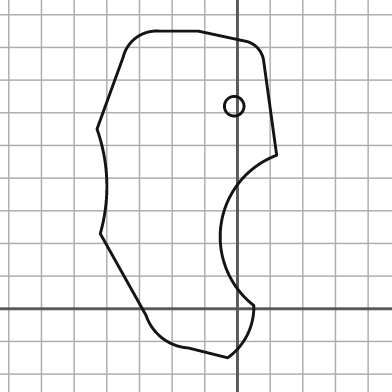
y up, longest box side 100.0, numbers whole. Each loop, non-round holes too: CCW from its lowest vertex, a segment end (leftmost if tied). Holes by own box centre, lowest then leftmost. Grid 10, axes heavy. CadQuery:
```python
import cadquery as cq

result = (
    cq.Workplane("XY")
    .moveTo(-3.0, -15.0)
    .threePointArc((3.0, -8.0), (5.0, 1.0))
    .threePointArc((-5.0, 26.0), (12.0, 47.0))
    .lineTo(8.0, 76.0)
    .threePointArc((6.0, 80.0), (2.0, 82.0))
    .lineTo(-12.0, 85.0)
    .lineTo(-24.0, 85.0)
    .threePointArc((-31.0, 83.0), (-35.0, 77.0))
    .lineTo(-43.0, 55.0)
    .threePointArc((-40.0, 39.0), (-42.0, 23.0))
    .lineTo(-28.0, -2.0)
    .threePointArc((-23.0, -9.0), (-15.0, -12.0))
    .close()
    .moveTo(-1.0, 62.0)
    .circle(3.0)
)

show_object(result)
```